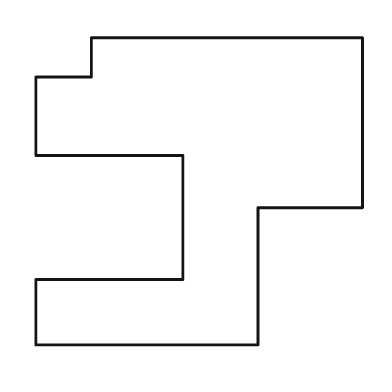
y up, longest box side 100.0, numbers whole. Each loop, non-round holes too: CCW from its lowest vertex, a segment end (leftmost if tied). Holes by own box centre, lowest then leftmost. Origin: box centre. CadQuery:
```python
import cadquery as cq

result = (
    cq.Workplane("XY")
    .moveTo(-50.0, -47.0)
    .lineTo(18.0, -47.0)
    .lineTo(18.0, -5.0)
    .lineTo(50.0, -5.0)
    .lineTo(50.0, 47.0)
    .lineTo(-33.0, 47.0)
    .lineTo(-33.0, 35.0)
    .lineTo(-50.0, 35.0)
    .lineTo(-50.0, 11.0)
    .lineTo(-5.0, 11.0)
    .lineTo(-5.0, -27.0)
    .lineTo(-50.0, -27.0)
    .close()
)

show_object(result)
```